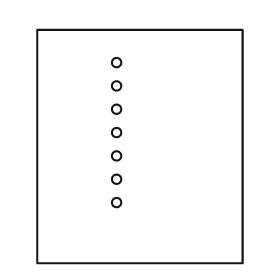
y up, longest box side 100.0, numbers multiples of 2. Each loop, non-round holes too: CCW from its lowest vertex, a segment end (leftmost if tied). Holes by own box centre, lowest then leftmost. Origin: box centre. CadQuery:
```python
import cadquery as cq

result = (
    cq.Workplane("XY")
    .moveTo(-44.0, -50.0)
    .lineTo(44.0, -50.0)
    .lineTo(44.0, 50.0)
    .lineTo(-44.0, 50.0)
    .close()
    .moveTo(-10.0, -24.0)
    .circle(2.0)
    .moveTo(-10.0, -14.0)
    .circle(2.0)
    .moveTo(-10.0, -4.0)
    .circle(2.0)
    .moveTo(-10.0, 6.0)
    .circle(2.0)
    .moveTo(-10.0, 16.0)
    .circle(2.0)
    .moveTo(-10.0, 26.0)
    .circle(2.0)
    .moveTo(-10.0, 36.0)
    .circle(2.0)
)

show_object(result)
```